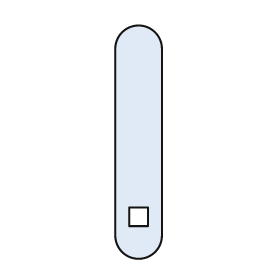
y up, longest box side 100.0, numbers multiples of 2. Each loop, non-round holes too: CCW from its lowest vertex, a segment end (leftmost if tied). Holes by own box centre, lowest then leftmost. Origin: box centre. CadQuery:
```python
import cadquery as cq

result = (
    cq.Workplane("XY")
    .moveTo(-10.0, -40.0)
    .threePointArc((0.0, -50.0), (10.0, -40.0))
    .lineTo(10.0, 40.0)
    .threePointArc((0.0, 50.0), (-10.0, 40.0))
    .close()
    .moveTo(-4.0, -36.0)
    .lineTo(4.0, -36.0)
    .lineTo(4.0, -28.0)
    .lineTo(-4.0, -28.0)
    .close()
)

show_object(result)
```